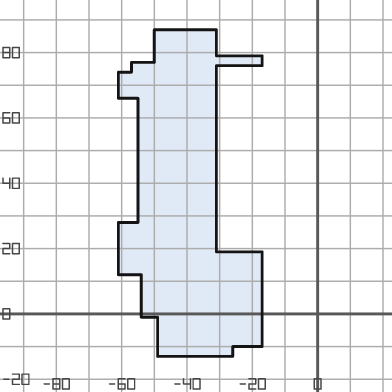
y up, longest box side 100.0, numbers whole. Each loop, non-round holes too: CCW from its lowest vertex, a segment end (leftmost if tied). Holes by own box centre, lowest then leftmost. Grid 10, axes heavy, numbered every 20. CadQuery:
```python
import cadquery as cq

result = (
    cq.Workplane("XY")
    .moveTo(-49.0, -13.0)
    .lineTo(-26.0, -13.0)
    .lineTo(-26.0, -10.0)
    .lineTo(-17.0, -10.0)
    .lineTo(-17.0, 19.0)
    .lineTo(-31.0, 19.0)
    .lineTo(-31.0, 76.0)
    .lineTo(-17.0, 76.0)
    .lineTo(-17.0, 79.0)
    .lineTo(-31.0, 79.0)
    .lineTo(-31.0, 87.0)
    .lineTo(-50.0, 87.0)
    .lineTo(-50.0, 77.0)
    .lineTo(-57.0, 77.0)
    .lineTo(-57.0, 74.0)
    .lineTo(-61.0, 74.0)
    .lineTo(-61.0, 66.0)
    .lineTo(-55.0, 66.0)
    .lineTo(-55.0, 28.0)
    .lineTo(-61.0, 28.0)
    .lineTo(-61.0, 12.0)
    .lineTo(-54.0, 12.0)
    .lineTo(-54.0, -1.0)
    .lineTo(-49.0, -1.0)
    .close()
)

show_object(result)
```